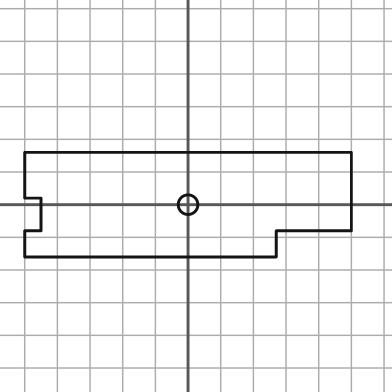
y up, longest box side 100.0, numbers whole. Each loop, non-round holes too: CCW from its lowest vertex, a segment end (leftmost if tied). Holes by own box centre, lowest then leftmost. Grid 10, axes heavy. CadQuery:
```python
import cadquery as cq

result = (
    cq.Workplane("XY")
    .moveTo(-50.0, -16.0)
    .lineTo(27.0, -16.0)
    .lineTo(27.0, -8.0)
    .lineTo(50.0, -8.0)
    .lineTo(50.0, 16.0)
    .lineTo(-50.0, 16.0)
    .lineTo(-50.0, 2.0)
    .lineTo(-45.0, 2.0)
    .lineTo(-45.0, -8.0)
    .lineTo(-50.0, -8.0)
    .close()
    .moveTo(0.0, 0.0)
    .circle(3.0)
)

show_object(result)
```